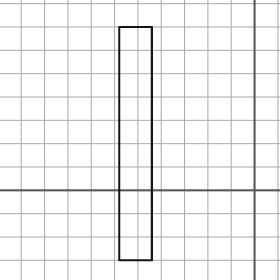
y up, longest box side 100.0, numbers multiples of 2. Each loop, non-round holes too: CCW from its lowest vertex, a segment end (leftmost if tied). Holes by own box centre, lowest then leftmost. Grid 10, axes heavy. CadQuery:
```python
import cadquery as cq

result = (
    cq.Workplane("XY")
    .moveTo(-58.0, -30.0)
    .lineTo(-44.0, -30.0)
    .lineTo(-44.0, 70.0)
    .lineTo(-58.0, 70.0)
    .close()
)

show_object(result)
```